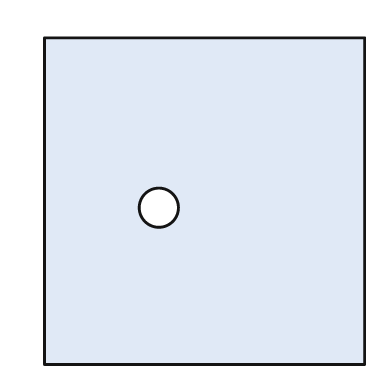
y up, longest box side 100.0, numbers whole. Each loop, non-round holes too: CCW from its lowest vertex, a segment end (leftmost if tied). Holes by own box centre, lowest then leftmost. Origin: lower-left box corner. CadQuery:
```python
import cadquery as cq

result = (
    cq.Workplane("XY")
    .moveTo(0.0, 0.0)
    .lineTo(98.0, 0.0)
    .lineTo(98.0, 100.0)
    .lineTo(0.0, 100.0)
    .close()
    .moveTo(35.0, 48.0)
    .circle(6.0)
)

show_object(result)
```